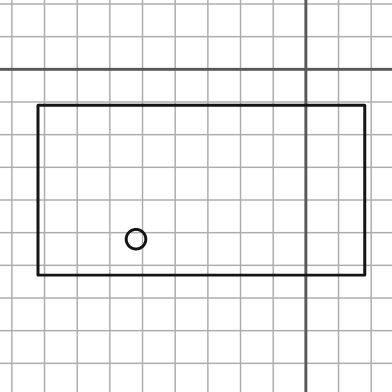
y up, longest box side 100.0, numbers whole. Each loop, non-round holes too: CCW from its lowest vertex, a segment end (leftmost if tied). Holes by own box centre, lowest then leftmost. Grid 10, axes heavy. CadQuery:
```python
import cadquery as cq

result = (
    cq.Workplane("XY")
    .moveTo(-82.0, -63.0)
    .lineTo(18.0, -63.0)
    .lineTo(18.0, -11.0)
    .lineTo(-82.0, -11.0)
    .close()
    .moveTo(-52.0, -52.0)
    .circle(3.0)
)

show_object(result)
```